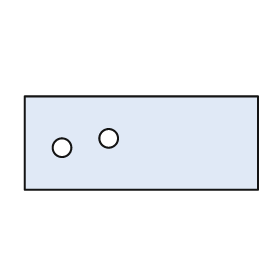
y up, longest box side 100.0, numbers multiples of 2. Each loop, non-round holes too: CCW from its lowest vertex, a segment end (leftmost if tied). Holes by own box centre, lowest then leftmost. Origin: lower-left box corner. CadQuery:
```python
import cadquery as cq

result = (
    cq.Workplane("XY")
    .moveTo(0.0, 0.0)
    .lineTo(100.0, 0.0)
    .lineTo(100.0, 40.0)
    .lineTo(0.0, 40.0)
    .close()
    .moveTo(16.0, 18.0)
    .circle(4.0)
    .moveTo(36.0, 22.0)
    .circle(4.0)
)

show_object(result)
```